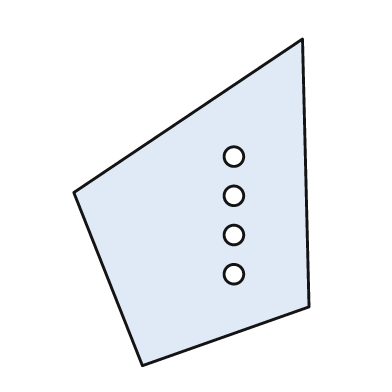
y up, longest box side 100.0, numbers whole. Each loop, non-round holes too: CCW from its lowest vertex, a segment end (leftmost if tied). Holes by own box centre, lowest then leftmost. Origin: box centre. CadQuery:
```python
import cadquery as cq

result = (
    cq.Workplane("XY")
    .moveTo(-15.0, -50.0)
    .lineTo(36.0, -32.0)
    .lineTo(34.0, 50.0)
    .lineTo(-36.0, 3.0)
    .close()
    .moveTo(13.0, -22.0)
    .circle(3.0)
    .moveTo(13.0, -10.0)
    .circle(3.0)
    .moveTo(13.0, 2.0)
    .circle(3.0)
    .moveTo(13.0, 14.0)
    .circle(3.0)
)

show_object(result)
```